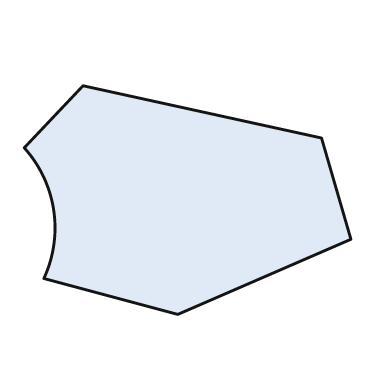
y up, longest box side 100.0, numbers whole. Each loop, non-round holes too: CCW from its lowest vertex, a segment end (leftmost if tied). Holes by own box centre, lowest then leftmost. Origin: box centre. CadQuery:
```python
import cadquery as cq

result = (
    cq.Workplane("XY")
    .moveTo(-3.0, -35.0)
    .lineTo(50.0, -12.0)
    .lineTo(41.0, 19.0)
    .lineTo(-32.0, 35.0)
    .lineTo(-50.0, 16.0)
    .threePointArc((-41.0, -3.0), (-44.0, -24.0))
    .close()
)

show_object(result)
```